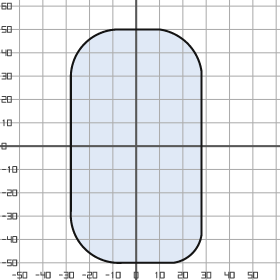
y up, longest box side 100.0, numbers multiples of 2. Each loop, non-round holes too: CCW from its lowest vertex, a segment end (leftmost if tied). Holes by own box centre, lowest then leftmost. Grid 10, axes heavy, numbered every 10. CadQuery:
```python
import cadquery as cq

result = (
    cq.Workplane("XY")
    .moveTo(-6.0, -50.0)
    .lineTo(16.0, -50.0)
    .threePointArc((24.0, -46.0), (28.0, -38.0))
    .lineTo(28.0, 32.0)
    .threePointArc((22.0, 44.0), (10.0, 50.0))
    .lineTo(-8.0, 50.0)
    .threePointArc((-22.0, 44.0), (-28.0, 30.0))
    .lineTo(-28.0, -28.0)
    .threePointArc((-22.0, -44.0), (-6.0, -50.0))
    .close()
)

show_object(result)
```